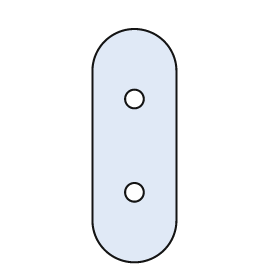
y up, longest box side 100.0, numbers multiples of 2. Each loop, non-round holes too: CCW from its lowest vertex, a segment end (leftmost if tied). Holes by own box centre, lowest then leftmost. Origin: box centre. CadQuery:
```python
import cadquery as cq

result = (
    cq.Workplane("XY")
    .moveTo(-18.0, -32.0)
    .threePointArc((0.0, -50.0), (18.0, -32.0))
    .lineTo(18.0, 32.0)
    .threePointArc((0.0, 50.0), (-18.0, 32.0))
    .close()
    .moveTo(0.0, -20.0)
    .circle(4.0)
    .moveTo(0.0, 20.0)
    .circle(4.0)
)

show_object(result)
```